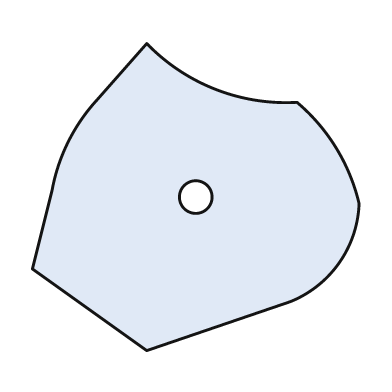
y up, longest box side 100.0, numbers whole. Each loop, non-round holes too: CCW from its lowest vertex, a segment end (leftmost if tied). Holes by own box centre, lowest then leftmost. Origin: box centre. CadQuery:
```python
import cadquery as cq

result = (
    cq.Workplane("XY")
    .moveTo(-15.0, -47.0)
    .lineTo(29.0, -32.0)
    .threePointArc((44.0, -20.0), (50.0, -2.0))
    .threePointArc((43.0, 15.0), (31.0, 29.0))
    .threePointArc((6.0, 33.0), (-15.0, 47.0))
    .lineTo(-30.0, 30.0)
    .threePointArc((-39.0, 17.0), (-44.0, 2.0))
    .lineTo(-50.0, -22.0)
    .close()
    .moveTo(0.0, 0.0)
    .circle(5.0)
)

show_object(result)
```